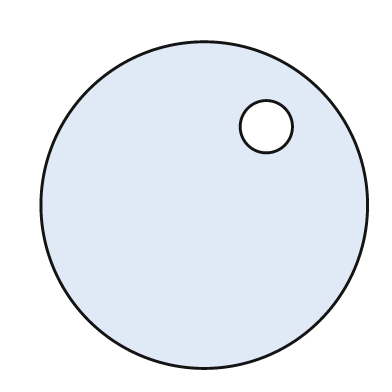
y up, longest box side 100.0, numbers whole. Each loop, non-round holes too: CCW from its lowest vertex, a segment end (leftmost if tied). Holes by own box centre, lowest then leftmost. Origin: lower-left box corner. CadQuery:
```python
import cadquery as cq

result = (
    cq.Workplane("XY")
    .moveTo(50.0, 50.0)
    .circle(50.0)
    .moveTo(69.0, 74.0)
    .circle(8.0)
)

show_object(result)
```